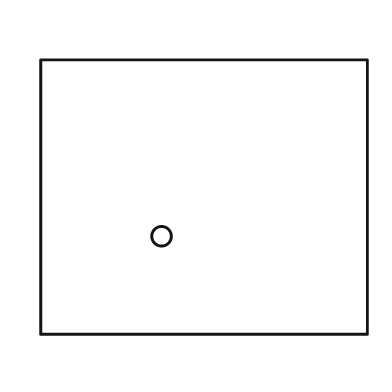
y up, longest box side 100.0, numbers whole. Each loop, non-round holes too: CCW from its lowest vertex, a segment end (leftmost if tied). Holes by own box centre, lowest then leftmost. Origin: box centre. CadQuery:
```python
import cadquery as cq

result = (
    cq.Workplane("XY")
    .moveTo(-50.0, -42.0)
    .lineTo(50.0, -42.0)
    .lineTo(50.0, 42.0)
    .lineTo(-50.0, 42.0)
    .close()
    .moveTo(-13.0, -12.0)
    .circle(3.0)
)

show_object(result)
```